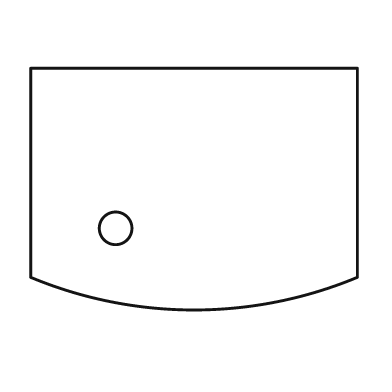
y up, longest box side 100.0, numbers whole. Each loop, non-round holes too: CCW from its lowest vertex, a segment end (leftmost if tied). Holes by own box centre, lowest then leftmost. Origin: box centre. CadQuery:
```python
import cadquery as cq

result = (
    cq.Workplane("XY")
    .moveTo(-50.0, -27.0)
    .threePointArc((0.0, -37.0), (50.0, -27.0))
    .lineTo(50.0, 37.0)
    .lineTo(-50.0, 37.0)
    .close()
    .moveTo(-24.0, -12.0)
    .circle(5.0)
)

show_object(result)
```